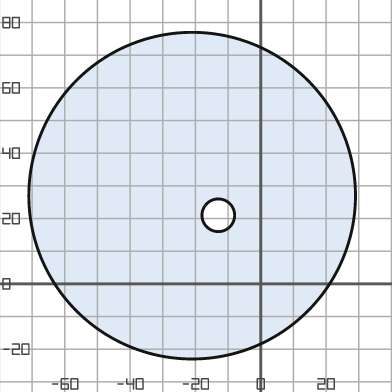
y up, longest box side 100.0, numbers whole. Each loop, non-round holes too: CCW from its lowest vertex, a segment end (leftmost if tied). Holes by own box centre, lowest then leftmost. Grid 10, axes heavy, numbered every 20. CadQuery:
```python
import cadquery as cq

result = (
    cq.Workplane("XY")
    .moveTo(-21.0, 27.0)
    .circle(50.0)
    .moveTo(-13.0, 21.0)
    .circle(5.0)
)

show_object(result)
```